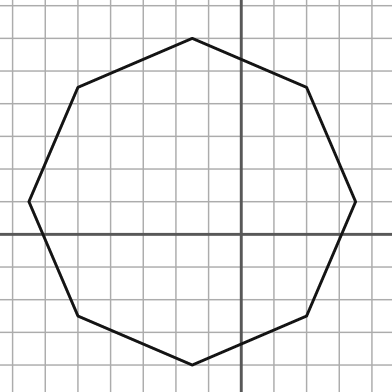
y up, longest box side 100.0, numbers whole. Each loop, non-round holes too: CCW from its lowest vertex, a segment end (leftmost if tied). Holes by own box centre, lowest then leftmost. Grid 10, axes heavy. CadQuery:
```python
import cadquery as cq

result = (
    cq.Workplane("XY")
    .moveTo(-15.0, -40.0)
    .lineTo(20.0, -25.0)
    .lineTo(35.0, 10.0)
    .lineTo(20.0, 45.0)
    .lineTo(-15.0, 60.0)
    .lineTo(-50.0, 45.0)
    .lineTo(-65.0, 10.0)
    .lineTo(-50.0, -25.0)
    .close()
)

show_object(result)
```